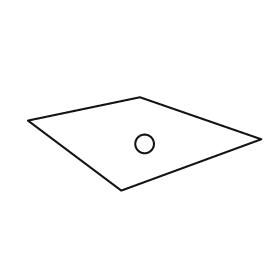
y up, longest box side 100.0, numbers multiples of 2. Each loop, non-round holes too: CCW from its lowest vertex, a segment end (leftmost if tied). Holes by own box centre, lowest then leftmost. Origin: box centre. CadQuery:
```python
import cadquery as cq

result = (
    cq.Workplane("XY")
    .moveTo(-10.0, -20.0)
    .lineTo(50.0, 2.0)
    .lineTo(-2.0, 20.0)
    .lineTo(-50.0, 10.0)
    .close()
    .moveTo(0.0, 0.0)
    .circle(4.0)
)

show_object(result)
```